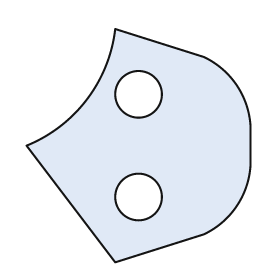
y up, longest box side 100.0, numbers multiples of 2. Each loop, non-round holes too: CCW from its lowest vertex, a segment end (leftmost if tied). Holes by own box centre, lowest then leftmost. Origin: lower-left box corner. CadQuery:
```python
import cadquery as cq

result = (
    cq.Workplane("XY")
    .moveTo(38.0, 0.0)
    .lineTo(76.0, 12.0)
    .threePointArc((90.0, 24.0), (96.0, 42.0))
    .lineTo(96.0, 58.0)
    .threePointArc((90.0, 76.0), (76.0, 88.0))
    .lineTo(38.0, 100.0)
    .threePointArc((26.0, 70.0), (0.0, 50.0))
    .close()
    .moveTo(48.0, 28.0)
    .circle(10.0)
    .moveTo(48.0, 72.0)
    .circle(10.0)
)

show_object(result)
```